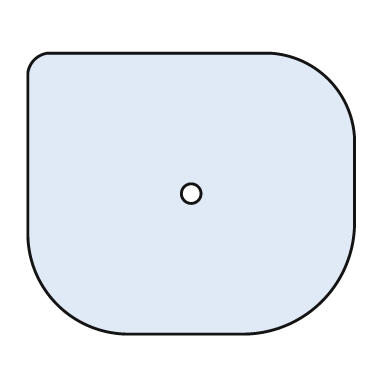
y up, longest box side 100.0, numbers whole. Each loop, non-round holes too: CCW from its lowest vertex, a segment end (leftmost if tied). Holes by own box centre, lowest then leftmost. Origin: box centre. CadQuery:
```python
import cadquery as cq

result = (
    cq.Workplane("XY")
    .moveTo(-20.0, -43.0)
    .lineTo(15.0, -43.0)
    .threePointArc((40.0, -33.0), (50.0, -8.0))
    .lineTo(50.0, 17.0)
    .threePointArc((42.0, 35.0), (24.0, 43.0))
    .lineTo(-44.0, 43.0)
    .threePointArc((-48.0, 41.0), (-50.0, 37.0))
    .lineTo(-50.0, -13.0)
    .threePointArc((-41.0, -34.0), (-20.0, -43.0))
    .close()
    .moveTo(0.0, 0.0)
    .circle(3.0)
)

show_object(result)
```